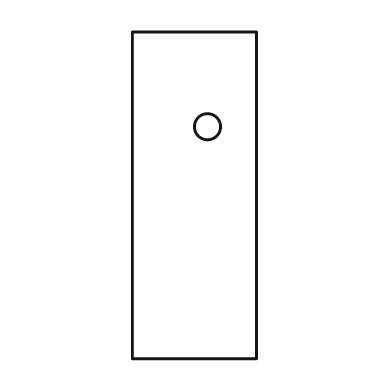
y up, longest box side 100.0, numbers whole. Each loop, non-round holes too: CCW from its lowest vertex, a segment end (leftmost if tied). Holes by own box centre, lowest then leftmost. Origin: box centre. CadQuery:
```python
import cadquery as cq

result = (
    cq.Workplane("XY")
    .moveTo(-19.0, -50.0)
    .lineTo(19.0, -50.0)
    .lineTo(19.0, 50.0)
    .lineTo(-19.0, 50.0)
    .close()
    .moveTo(4.0, 21.0)
    .circle(4.0)
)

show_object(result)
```